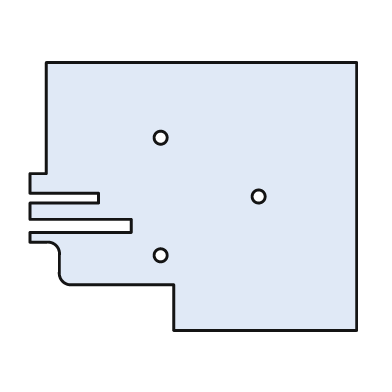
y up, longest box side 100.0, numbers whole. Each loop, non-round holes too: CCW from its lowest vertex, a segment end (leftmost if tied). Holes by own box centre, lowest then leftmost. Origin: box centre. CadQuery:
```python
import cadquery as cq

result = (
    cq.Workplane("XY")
    .moveTo(-6.0, -41.0)
    .lineTo(50.0, -41.0)
    .lineTo(50.0, 41.0)
    .lineTo(-45.0, 41.0)
    .lineTo(-45.0, 7.0)
    .lineTo(-50.0, 7.0)
    .lineTo(-50.0, 1.0)
    .lineTo(-29.0, 1.0)
    .lineTo(-29.0, -2.0)
    .lineTo(-50.0, -2.0)
    .lineTo(-50.0, -7.0)
    .lineTo(-19.0, -7.0)
    .lineTo(-19.0, -11.0)
    .lineTo(-50.0, -11.0)
    .lineTo(-50.0, -14.0)
    .lineTo(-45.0, -14.0)
    .threePointArc((-42.0, -15.0), (-41.0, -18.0))
    .lineTo(-41.0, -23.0)
    .threePointArc((-40.0, -26.0), (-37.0, -27.0))
    .lineTo(-6.0, -27.0)
    .close()
    .moveTo(-10.0, -18.0)
    .circle(2.0)
    .moveTo(20.0, 0.0)
    .circle(2.0)
    .moveTo(-10.0, 18.0)
    .circle(2.0)
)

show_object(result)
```